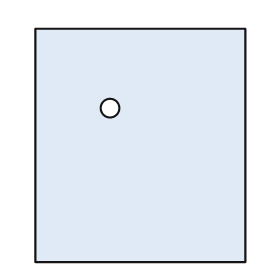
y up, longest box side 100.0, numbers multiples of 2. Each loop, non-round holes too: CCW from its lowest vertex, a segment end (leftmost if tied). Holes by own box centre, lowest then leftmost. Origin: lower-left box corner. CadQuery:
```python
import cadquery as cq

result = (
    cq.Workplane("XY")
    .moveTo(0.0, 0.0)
    .lineTo(90.0, 0.0)
    .lineTo(90.0, 100.0)
    .lineTo(0.0, 100.0)
    .close()
    .moveTo(32.0, 66.0)
    .circle(4.0)
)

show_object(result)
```